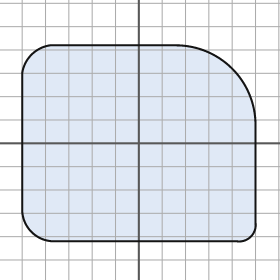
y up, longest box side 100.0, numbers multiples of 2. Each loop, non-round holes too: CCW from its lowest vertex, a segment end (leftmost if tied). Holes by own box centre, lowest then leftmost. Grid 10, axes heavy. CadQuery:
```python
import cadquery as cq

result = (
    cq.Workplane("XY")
    .moveTo(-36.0, -42.0)
    .lineTo(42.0, -42.0)
    .threePointArc((48.0, -40.0), (50.0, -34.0))
    .lineTo(50.0, 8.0)
    .threePointArc((40.0, 32.0), (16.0, 42.0))
    .lineTo(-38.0, 42.0)
    .threePointArc((-46.0, 38.0), (-50.0, 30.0))
    .lineTo(-50.0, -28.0)
    .threePointArc((-46.0, -38.0), (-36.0, -42.0))
    .close()
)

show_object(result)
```